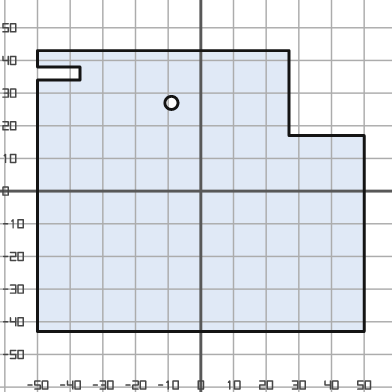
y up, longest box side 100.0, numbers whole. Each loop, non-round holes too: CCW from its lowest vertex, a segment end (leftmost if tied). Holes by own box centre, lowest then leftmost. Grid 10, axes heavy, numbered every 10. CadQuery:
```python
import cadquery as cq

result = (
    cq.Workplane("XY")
    .moveTo(-50.0, -43.0)
    .lineTo(50.0, -43.0)
    .lineTo(50.0, 17.0)
    .lineTo(27.0, 17.0)
    .lineTo(27.0, 43.0)
    .lineTo(-50.0, 43.0)
    .lineTo(-50.0, 38.0)
    .lineTo(-37.0, 38.0)
    .lineTo(-37.0, 34.0)
    .lineTo(-50.0, 34.0)
    .close()
    .moveTo(-9.0, 27.0)
    .circle(2.0)
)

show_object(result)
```